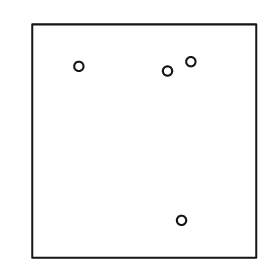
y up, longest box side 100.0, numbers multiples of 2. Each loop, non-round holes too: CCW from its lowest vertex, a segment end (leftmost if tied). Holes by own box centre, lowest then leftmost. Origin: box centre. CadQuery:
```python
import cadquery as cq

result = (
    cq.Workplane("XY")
    .moveTo(-48.0, -50.0)
    .lineTo(48.0, -50.0)
    .lineTo(48.0, 50.0)
    .lineTo(-48.0, 50.0)
    .close()
    .moveTo(16.0, -34.0)
    .circle(2.0)
    .moveTo(10.0, 30.0)
    .circle(2.0)
    .moveTo(-28.0, 32.0)
    .circle(2.0)
    .moveTo(20.0, 34.0)
    .circle(2.0)
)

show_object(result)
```